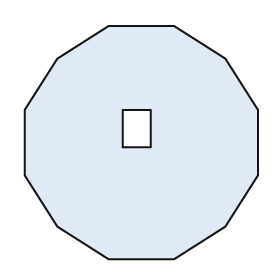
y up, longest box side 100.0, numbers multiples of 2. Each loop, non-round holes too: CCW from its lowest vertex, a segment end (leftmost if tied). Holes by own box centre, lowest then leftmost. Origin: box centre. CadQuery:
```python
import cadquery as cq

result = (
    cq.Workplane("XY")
    .moveTo(-14.0, -50.0)
    .lineTo(14.0, -50.0)
    .lineTo(36.0, -36.0)
    .lineTo(50.0, -14.0)
    .lineTo(50.0, 14.0)
    .lineTo(36.0, 36.0)
    .lineTo(14.0, 50.0)
    .lineTo(-14.0, 50.0)
    .lineTo(-36.0, 36.0)
    .lineTo(-50.0, 14.0)
    .lineTo(-50.0, -14.0)
    .lineTo(-36.0, -36.0)
    .close()
    .moveTo(-8.0, -2.0)
    .lineTo(4.0, -2.0)
    .lineTo(4.0, 14.0)
    .lineTo(-8.0, 14.0)
    .close()
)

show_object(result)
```